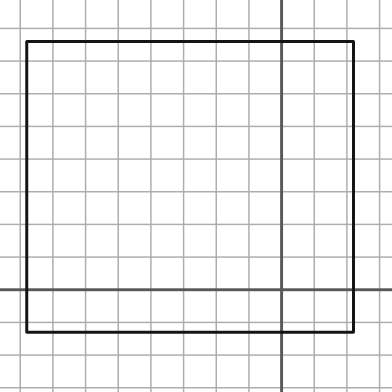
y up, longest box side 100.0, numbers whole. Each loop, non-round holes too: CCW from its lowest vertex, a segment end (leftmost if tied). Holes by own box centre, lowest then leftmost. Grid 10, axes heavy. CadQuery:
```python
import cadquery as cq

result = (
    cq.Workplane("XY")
    .moveTo(-78.0, -13.0)
    .lineTo(22.0, -13.0)
    .lineTo(22.0, 76.0)
    .lineTo(-78.0, 76.0)
    .close()
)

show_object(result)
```